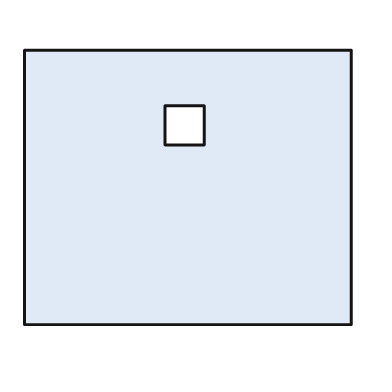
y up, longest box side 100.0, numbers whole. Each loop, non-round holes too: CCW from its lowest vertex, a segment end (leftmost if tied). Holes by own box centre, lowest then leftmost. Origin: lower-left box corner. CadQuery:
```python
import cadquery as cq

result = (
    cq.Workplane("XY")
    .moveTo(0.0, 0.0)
    .lineTo(100.0, 0.0)
    .lineTo(100.0, 84.0)
    .lineTo(0.0, 84.0)
    .close()
    .moveTo(43.0, 55.0)
    .lineTo(55.0, 55.0)
    .lineTo(55.0, 67.0)
    .lineTo(43.0, 67.0)
    .close()
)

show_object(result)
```